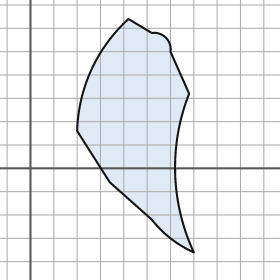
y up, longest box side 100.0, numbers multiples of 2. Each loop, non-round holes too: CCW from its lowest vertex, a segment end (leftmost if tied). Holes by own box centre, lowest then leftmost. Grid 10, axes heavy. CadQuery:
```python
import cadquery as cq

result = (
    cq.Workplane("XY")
    .moveTo(70.0, -36.0)
    .threePointArc((62.0, -2.0), (68.0, 32.0))
    .lineTo(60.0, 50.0)
    .threePointArc((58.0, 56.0), (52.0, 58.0))
    .lineTo(42.0, 64.0)
    .threePointArc((26.0, 42.0), (20.0, 16.0))
    .lineTo(34.0, -6.0)
    .lineTo(52.0, -22.0)
    .threePointArc((60.0, -30.0), (70.0, -36.0))
    .close()
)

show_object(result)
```